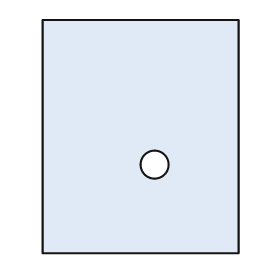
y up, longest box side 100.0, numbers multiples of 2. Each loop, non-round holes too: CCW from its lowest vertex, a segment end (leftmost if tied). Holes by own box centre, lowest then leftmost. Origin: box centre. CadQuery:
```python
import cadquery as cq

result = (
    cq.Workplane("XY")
    .moveTo(-42.0, -50.0)
    .lineTo(42.0, -50.0)
    .lineTo(42.0, 50.0)
    .lineTo(-42.0, 50.0)
    .close()
    .moveTo(6.0, -12.0)
    .circle(6.0)
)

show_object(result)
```